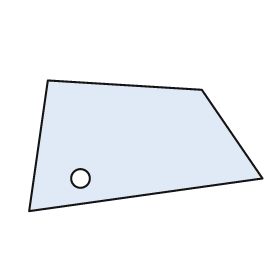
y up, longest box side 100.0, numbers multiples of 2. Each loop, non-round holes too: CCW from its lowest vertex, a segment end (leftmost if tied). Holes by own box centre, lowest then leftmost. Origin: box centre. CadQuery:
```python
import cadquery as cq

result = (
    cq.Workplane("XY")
    .moveTo(-50.0, -28.0)
    .lineTo(50.0, -14.0)
    .lineTo(24.0, 24.0)
    .lineTo(-42.0, 28.0)
    .close()
    .moveTo(-28.0, -14.0)
    .circle(4.0)
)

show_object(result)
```